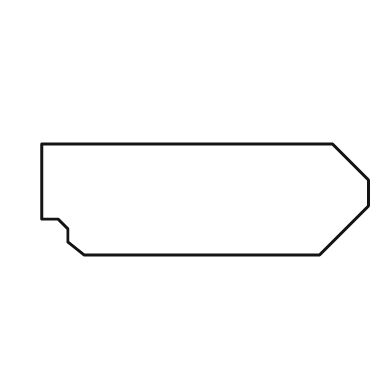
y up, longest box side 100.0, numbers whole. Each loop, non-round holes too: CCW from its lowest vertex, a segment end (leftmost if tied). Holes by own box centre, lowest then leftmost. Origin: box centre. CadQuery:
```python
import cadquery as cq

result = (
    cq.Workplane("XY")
    .moveTo(-37.0, -17.0)
    .lineTo(35.0, -17.0)
    .lineTo(50.0, -2.0)
    .lineTo(50.0, 6.0)
    .lineTo(39.0, 17.0)
    .lineTo(-50.0, 17.0)
    .lineTo(-50.0, -6.0)
    .lineTo(-45.0, -6.0)
    .lineTo(-42.0, -9.0)
    .lineTo(-42.0, -13.0)
    .close()
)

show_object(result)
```